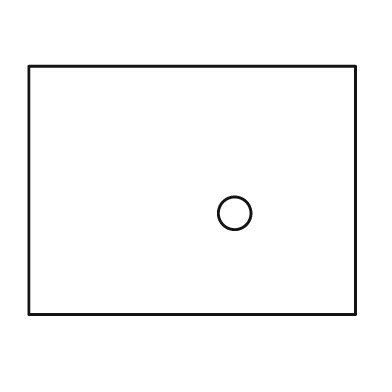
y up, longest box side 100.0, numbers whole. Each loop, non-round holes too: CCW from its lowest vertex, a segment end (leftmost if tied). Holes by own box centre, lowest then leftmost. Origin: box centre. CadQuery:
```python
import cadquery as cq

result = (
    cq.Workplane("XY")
    .moveTo(-50.0, -38.0)
    .lineTo(50.0, -38.0)
    .lineTo(50.0, 38.0)
    .lineTo(-50.0, 38.0)
    .close()
    .moveTo(13.0, -7.0)
    .circle(5.0)
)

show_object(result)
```